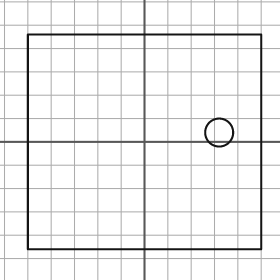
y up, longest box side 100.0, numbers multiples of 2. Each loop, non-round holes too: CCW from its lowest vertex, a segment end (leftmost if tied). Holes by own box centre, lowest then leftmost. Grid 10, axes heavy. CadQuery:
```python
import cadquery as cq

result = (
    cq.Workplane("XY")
    .moveTo(-50.0, -46.0)
    .lineTo(50.0, -46.0)
    .lineTo(50.0, 46.0)
    .lineTo(-50.0, 46.0)
    .close()
    .moveTo(32.0, 4.0)
    .circle(6.0)
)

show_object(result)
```